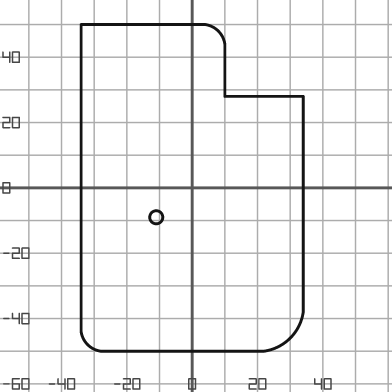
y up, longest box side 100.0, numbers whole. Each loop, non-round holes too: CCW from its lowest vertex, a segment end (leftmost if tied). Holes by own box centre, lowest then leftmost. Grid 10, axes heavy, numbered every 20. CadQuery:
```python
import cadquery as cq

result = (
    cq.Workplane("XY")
    .moveTo(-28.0, -50.0)
    .lineTo(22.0, -50.0)
    .threePointArc((30.0, -46.0), (34.0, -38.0))
    .lineTo(34.0, 28.0)
    .lineTo(10.0, 28.0)
    .lineTo(10.0, 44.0)
    .threePointArc((8.0, 48.0), (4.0, 50.0))
    .lineTo(-34.0, 50.0)
    .lineTo(-34.0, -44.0)
    .threePointArc((-32.0, -48.0), (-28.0, -50.0))
    .close()
    .moveTo(-11.0, -9.0)
    .circle(2.0)
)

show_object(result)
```